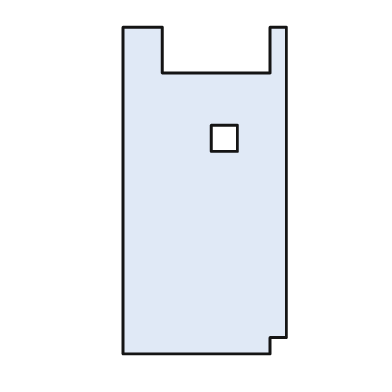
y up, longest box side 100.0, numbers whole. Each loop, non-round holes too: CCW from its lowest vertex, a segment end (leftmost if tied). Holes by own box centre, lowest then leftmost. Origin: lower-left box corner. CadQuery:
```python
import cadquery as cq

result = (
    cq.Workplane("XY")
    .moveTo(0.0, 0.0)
    .lineTo(45.0, 0.0)
    .lineTo(45.0, 5.0)
    .lineTo(50.0, 5.0)
    .lineTo(50.0, 100.0)
    .lineTo(45.0, 100.0)
    .lineTo(45.0, 86.0)
    .lineTo(12.0, 86.0)
    .lineTo(12.0, 100.0)
    .lineTo(0.0, 100.0)
    .close()
    .moveTo(27.0, 62.0)
    .lineTo(35.0, 62.0)
    .lineTo(35.0, 70.0)
    .lineTo(27.0, 70.0)
    .close()
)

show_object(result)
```